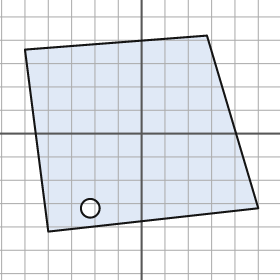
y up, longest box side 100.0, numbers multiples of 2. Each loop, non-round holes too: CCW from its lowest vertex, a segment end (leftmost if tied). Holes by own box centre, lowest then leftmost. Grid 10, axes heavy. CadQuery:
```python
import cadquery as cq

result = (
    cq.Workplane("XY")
    .moveTo(-40.0, -42.0)
    .lineTo(50.0, -32.0)
    .lineTo(28.0, 42.0)
    .lineTo(-50.0, 36.0)
    .close()
    .moveTo(-22.0, -32.0)
    .circle(4.0)
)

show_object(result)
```